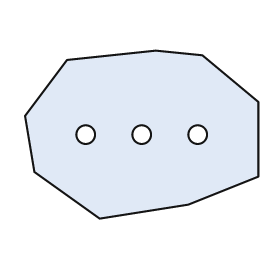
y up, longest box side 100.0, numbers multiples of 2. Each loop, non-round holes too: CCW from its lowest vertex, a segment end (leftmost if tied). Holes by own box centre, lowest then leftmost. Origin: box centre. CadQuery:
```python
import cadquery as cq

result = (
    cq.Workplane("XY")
    .moveTo(-18.0, -36.0)
    .lineTo(20.0, -30.0)
    .lineTo(50.0, -18.0)
    .lineTo(50.0, 14.0)
    .lineTo(26.0, 34.0)
    .lineTo(6.0, 36.0)
    .lineTo(-32.0, 32.0)
    .lineTo(-50.0, 8.0)
    .lineTo(-46.0, -16.0)
    .close()
    .moveTo(-24.0, 0.0)
    .circle(4.0)
    .moveTo(0.0, 0.0)
    .circle(4.0)
    .moveTo(24.0, 0.0)
    .circle(4.0)
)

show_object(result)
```